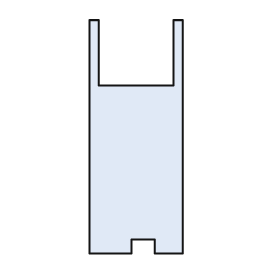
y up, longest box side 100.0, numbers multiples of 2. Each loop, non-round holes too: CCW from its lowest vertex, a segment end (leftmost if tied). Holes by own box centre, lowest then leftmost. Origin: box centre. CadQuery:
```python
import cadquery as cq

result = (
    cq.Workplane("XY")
    .moveTo(-20.0, -50.0)
    .lineTo(-2.0, -50.0)
    .lineTo(-2.0, -44.0)
    .lineTo(8.0, -44.0)
    .lineTo(8.0, -50.0)
    .lineTo(20.0, -50.0)
    .lineTo(20.0, 50.0)
    .lineTo(16.0, 50.0)
    .lineTo(16.0, 22.0)
    .lineTo(-16.0, 22.0)
    .lineTo(-16.0, 50.0)
    .lineTo(-20.0, 50.0)
    .close()
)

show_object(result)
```